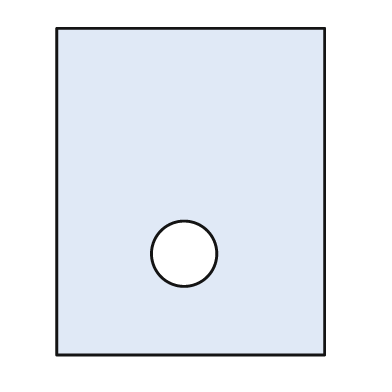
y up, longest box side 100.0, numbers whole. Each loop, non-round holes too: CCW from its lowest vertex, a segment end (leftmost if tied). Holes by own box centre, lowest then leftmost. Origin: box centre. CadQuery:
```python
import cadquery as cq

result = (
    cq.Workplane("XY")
    .moveTo(-41.0, -50.0)
    .lineTo(41.0, -50.0)
    .lineTo(41.0, 50.0)
    .lineTo(-41.0, 50.0)
    .close()
    .moveTo(-2.0, -19.0)
    .circle(10.0)
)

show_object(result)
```